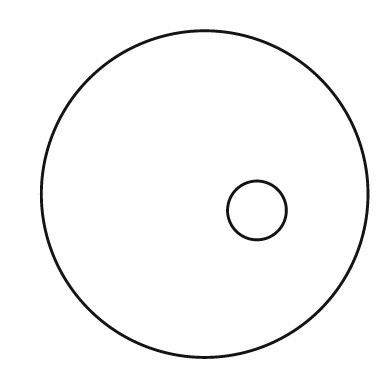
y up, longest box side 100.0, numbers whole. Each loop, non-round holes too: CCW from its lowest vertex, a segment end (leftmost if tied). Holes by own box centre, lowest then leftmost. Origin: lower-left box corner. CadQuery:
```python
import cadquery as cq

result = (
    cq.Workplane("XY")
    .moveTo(50.0, 50.0)
    .circle(50.0)
    .moveTo(66.0, 45.0)
    .circle(9.0)
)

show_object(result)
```